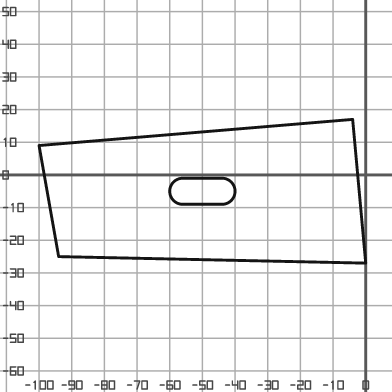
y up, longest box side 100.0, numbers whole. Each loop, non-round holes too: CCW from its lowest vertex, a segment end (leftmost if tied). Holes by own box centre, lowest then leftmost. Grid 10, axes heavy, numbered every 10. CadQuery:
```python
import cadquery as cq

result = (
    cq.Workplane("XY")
    .moveTo(0.0, -27.0)
    .lineTo(-4.0, 17.0)
    .lineTo(-100.0, 9.0)
    .lineTo(-94.0, -25.0)
    .close()
    .moveTo(-56.0, -9.0)
    .lineTo(-44.0, -9.0)
    .threePointArc((-40.0, -5.0), (-44.0, -1.0))
    .lineTo(-56.0, -1.0)
    .threePointArc((-60.0, -5.0), (-56.0, -9.0))
    .close()
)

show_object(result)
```